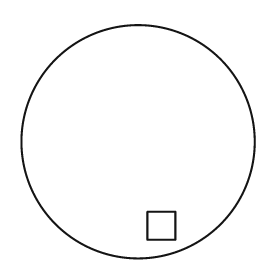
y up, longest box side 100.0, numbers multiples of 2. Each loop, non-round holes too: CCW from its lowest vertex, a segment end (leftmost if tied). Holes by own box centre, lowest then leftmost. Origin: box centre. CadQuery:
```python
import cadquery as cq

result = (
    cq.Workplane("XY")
    .moveTo(0.0, 0.0)
    .circle(50.0)
    .moveTo(4.0, -42.0)
    .lineTo(16.0, -42.0)
    .lineTo(16.0, -30.0)
    .lineTo(4.0, -30.0)
    .close()
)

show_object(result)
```